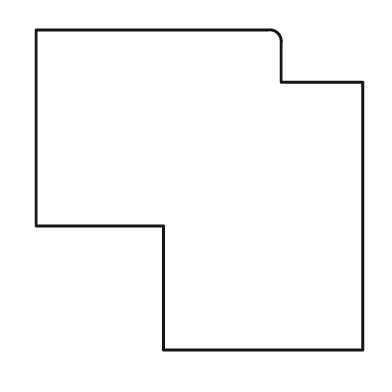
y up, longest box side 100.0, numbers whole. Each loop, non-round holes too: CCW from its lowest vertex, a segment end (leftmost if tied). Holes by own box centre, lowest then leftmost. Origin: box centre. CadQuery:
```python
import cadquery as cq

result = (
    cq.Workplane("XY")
    .moveTo(-11.0, -49.0)
    .lineTo(50.0, -49.0)
    .lineTo(50.0, 33.0)
    .lineTo(25.0, 33.0)
    .lineTo(25.0, 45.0)
    .threePointArc((24.0, 48.0), (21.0, 49.0))
    .lineTo(-50.0, 49.0)
    .lineTo(-50.0, -11.0)
    .lineTo(-11.0, -11.0)
    .close()
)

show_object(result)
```